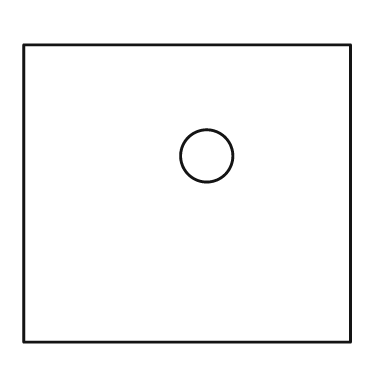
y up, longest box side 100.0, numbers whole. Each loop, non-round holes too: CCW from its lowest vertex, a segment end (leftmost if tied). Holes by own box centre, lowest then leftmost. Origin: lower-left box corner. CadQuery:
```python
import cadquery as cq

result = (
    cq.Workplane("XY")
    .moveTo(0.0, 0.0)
    .lineTo(100.0, 0.0)
    .lineTo(100.0, 91.0)
    .lineTo(0.0, 91.0)
    .close()
    .moveTo(56.0, 57.0)
    .circle(8.0)
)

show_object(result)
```